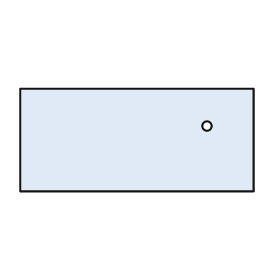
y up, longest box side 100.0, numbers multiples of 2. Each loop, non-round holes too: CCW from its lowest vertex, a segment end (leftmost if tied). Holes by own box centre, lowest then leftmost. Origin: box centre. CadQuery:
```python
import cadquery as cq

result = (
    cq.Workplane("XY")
    .moveTo(-50.0, -22.0)
    .lineTo(50.0, -22.0)
    .lineTo(50.0, 22.0)
    .lineTo(-50.0, 22.0)
    .close()
    .moveTo(30.0, 6.0)
    .circle(2.0)
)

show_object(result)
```